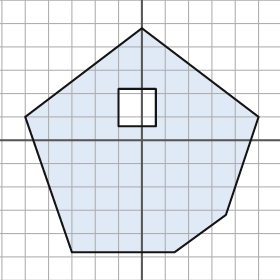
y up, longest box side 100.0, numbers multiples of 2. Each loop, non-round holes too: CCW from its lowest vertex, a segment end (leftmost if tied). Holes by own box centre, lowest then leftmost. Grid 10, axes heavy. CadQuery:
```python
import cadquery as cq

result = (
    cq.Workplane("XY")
    .moveTo(-30.0, -48.0)
    .lineTo(14.0, -48.0)
    .lineTo(36.0, -32.0)
    .lineTo(50.0, 10.0)
    .lineTo(0.0, 48.0)
    .lineTo(-50.0, 10.0)
    .close()
    .moveTo(-10.0, 6.0)
    .lineTo(6.0, 6.0)
    .lineTo(6.0, 22.0)
    .lineTo(-10.0, 22.0)
    .close()
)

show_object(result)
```